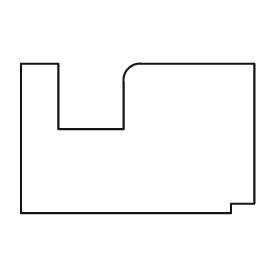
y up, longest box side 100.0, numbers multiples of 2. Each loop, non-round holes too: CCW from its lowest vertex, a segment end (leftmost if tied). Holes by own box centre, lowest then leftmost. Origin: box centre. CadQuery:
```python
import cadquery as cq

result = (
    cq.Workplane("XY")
    .moveTo(-50.0, -32.0)
    .lineTo(40.0, -32.0)
    .lineTo(40.0, -28.0)
    .lineTo(50.0, -28.0)
    .lineTo(50.0, 32.0)
    .lineTo(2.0, 32.0)
    .threePointArc((-4.0, 30.0), (-6.0, 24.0))
    .lineTo(-6.0, 4.0)
    .lineTo(-34.0, 4.0)
    .lineTo(-34.0, 32.0)
    .lineTo(-50.0, 32.0)
    .close()
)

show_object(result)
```